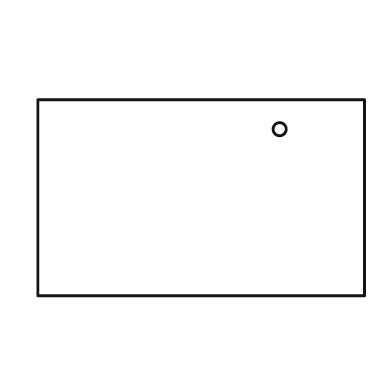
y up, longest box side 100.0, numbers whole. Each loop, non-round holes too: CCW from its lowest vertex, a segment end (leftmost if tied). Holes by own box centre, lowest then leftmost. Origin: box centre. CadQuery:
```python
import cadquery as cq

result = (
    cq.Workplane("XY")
    .moveTo(-50.0, -30.0)
    .lineTo(50.0, -30.0)
    .lineTo(50.0, 30.0)
    .lineTo(-50.0, 30.0)
    .close()
    .moveTo(24.0, 21.0)
    .circle(2.0)
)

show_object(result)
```